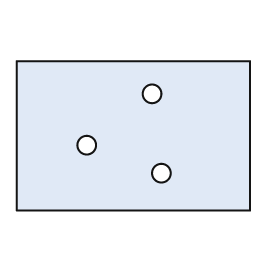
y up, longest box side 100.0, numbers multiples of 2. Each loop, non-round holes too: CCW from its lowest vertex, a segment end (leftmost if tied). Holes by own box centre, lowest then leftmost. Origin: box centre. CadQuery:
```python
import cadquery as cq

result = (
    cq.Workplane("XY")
    .moveTo(-50.0, -32.0)
    .lineTo(50.0, -32.0)
    .lineTo(50.0, 32.0)
    .lineTo(-50.0, 32.0)
    .close()
    .moveTo(12.0, -16.0)
    .circle(4.0)
    .moveTo(-20.0, -4.0)
    .circle(4.0)
    .moveTo(8.0, 18.0)
    .circle(4.0)
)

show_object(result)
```